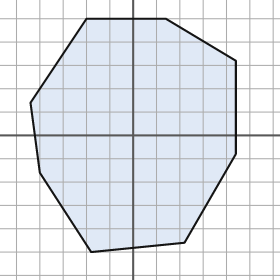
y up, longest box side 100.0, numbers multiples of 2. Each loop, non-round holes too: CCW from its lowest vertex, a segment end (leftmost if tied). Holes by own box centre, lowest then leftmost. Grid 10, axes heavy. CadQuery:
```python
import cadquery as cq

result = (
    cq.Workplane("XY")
    .moveTo(-18.0, -50.0)
    .lineTo(22.0, -46.0)
    .lineTo(44.0, -8.0)
    .lineTo(44.0, 32.0)
    .lineTo(14.0, 50.0)
    .lineTo(-20.0, 50.0)
    .lineTo(-44.0, 14.0)
    .lineTo(-40.0, -16.0)
    .close()
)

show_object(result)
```